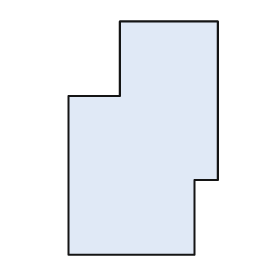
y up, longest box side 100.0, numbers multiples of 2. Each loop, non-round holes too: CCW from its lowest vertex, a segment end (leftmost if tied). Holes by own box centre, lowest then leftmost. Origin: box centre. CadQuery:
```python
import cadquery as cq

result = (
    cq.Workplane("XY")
    .moveTo(-32.0, -50.0)
    .lineTo(22.0, -50.0)
    .lineTo(22.0, -18.0)
    .lineTo(32.0, -18.0)
    .lineTo(32.0, 50.0)
    .lineTo(-10.0, 50.0)
    .lineTo(-10.0, 18.0)
    .lineTo(-32.0, 18.0)
    .close()
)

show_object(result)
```